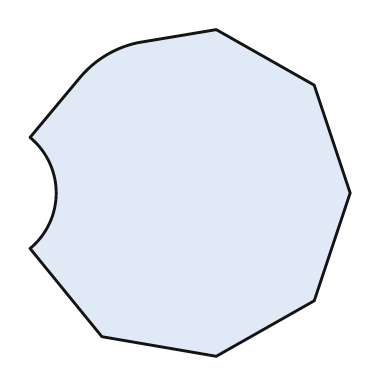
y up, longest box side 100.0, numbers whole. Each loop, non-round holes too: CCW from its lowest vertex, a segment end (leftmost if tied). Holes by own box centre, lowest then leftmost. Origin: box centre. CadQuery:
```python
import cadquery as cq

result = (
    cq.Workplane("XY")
    .moveTo(8.0, -50.0)
    .lineTo(38.0, -33.0)
    .lineTo(49.0, 0.0)
    .lineTo(38.0, 33.0)
    .lineTo(8.0, 50.0)
    .lineTo(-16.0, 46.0)
    .threePointArc((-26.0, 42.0), (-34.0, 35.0))
    .lineTo(-49.0, 17.0)
    .threePointArc((-41.0, 0.0), (-49.0, -17.0))
    .lineTo(-27.0, -44.0)
    .close()
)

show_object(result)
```